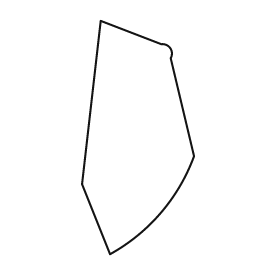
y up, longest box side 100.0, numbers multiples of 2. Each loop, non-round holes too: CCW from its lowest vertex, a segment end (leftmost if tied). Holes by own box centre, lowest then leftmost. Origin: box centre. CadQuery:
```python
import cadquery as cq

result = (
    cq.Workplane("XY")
    .moveTo(-12.0, -50.0)
    .threePointArc((10.0, -32.0), (24.0, -8.0))
    .lineTo(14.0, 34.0)
    .threePointArc((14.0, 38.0), (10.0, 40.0))
    .lineTo(-16.0, 50.0)
    .lineTo(-24.0, -20.0)
    .close()
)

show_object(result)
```